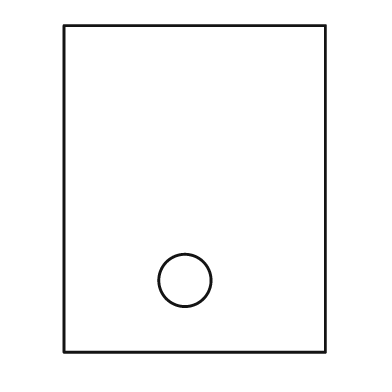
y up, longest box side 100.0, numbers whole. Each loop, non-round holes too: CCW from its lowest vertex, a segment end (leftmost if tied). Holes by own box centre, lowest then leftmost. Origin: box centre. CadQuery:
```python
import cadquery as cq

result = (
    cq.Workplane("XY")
    .moveTo(-40.0, -50.0)
    .lineTo(40.0, -50.0)
    .lineTo(40.0, 50.0)
    .lineTo(-40.0, 50.0)
    .close()
    .moveTo(-3.0, -28.0)
    .circle(8.0)
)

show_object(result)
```